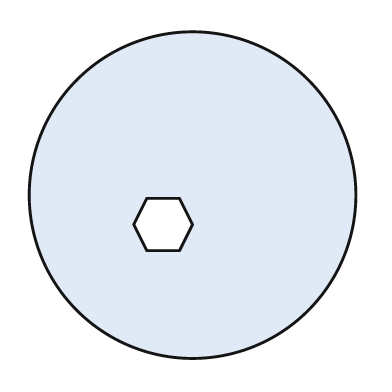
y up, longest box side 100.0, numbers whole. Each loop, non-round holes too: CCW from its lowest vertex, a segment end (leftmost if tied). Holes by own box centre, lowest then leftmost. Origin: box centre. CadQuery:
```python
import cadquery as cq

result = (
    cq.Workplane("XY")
    .moveTo(0.0, 0.0)
    .circle(50.0)
    .moveTo(-14.0, -17.0)
    .lineTo(-4.0, -17.0)
    .lineTo(0.0, -9.0)
    .lineTo(-4.0, -1.0)
    .lineTo(-14.0, -1.0)
    .lineTo(-18.0, -9.0)
    .close()
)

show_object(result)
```